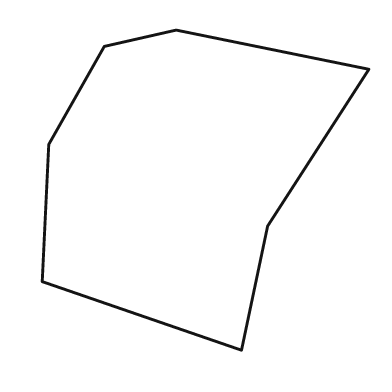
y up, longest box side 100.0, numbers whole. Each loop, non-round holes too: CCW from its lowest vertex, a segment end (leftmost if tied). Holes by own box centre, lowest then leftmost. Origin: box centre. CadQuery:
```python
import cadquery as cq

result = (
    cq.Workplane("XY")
    .moveTo(11.0, -49.0)
    .lineTo(19.0, -11.0)
    .lineTo(50.0, 37.0)
    .lineTo(-9.0, 49.0)
    .lineTo(-31.0, 44.0)
    .lineTo(-48.0, 14.0)
    .lineTo(-50.0, -28.0)
    .close()
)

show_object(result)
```